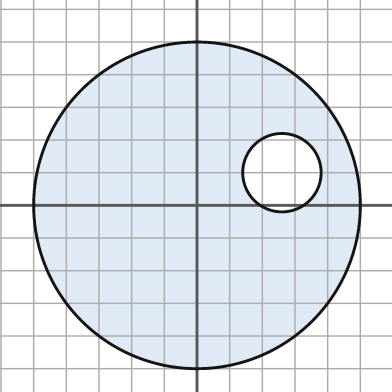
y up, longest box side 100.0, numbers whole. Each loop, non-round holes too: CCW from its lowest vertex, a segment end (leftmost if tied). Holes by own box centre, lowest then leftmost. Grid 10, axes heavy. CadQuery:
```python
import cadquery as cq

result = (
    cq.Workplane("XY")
    .moveTo(0.0, 0.0)
    .circle(50.0)
    .moveTo(26.0, 10.0)
    .circle(12.0)
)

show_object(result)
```